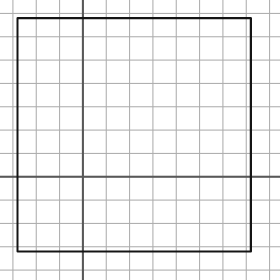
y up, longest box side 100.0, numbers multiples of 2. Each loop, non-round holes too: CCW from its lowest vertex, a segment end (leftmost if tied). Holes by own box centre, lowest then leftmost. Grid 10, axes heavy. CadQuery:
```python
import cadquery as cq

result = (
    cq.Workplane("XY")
    .moveTo(-28.0, -32.0)
    .lineTo(72.0, -32.0)
    .lineTo(72.0, 68.0)
    .lineTo(-28.0, 68.0)
    .close()
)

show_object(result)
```